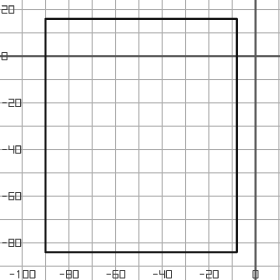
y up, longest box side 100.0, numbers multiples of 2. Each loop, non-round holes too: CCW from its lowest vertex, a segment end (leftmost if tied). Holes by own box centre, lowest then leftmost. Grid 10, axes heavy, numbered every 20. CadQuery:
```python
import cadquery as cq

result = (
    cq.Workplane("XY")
    .moveTo(-90.0, -84.0)
    .lineTo(-8.0, -84.0)
    .lineTo(-8.0, 16.0)
    .lineTo(-90.0, 16.0)
    .close()
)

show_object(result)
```